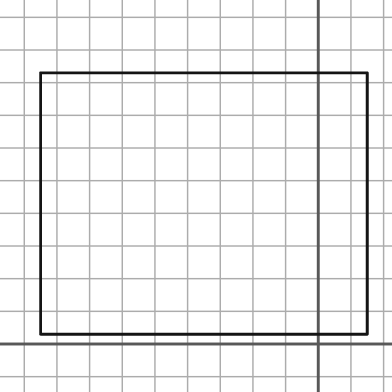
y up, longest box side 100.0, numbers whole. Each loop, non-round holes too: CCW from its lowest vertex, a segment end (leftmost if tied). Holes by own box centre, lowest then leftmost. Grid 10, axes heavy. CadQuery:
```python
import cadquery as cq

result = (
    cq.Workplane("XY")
    .moveTo(-85.0, 3.0)
    .lineTo(15.0, 3.0)
    .lineTo(15.0, 83.0)
    .lineTo(-85.0, 83.0)
    .close()
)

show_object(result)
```